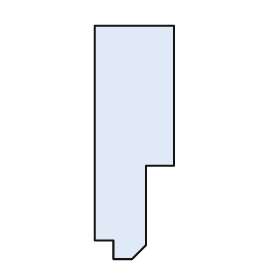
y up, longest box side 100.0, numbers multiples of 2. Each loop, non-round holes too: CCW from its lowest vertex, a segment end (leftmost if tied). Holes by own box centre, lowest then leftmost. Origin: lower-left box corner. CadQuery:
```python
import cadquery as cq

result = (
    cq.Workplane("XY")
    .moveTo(8.0, 0.0)
    .lineTo(16.0, 0.0)
    .lineTo(22.0, 6.0)
    .lineTo(22.0, 40.0)
    .lineTo(34.0, 40.0)
    .lineTo(34.0, 100.0)
    .lineTo(0.0, 100.0)
    .lineTo(0.0, 8.0)
    .lineTo(8.0, 8.0)
    .close()
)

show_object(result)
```